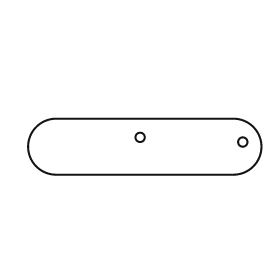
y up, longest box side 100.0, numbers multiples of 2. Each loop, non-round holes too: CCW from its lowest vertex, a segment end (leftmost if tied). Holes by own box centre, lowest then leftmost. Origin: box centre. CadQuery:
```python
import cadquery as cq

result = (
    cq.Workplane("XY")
    .moveTo(-38.0, -12.0)
    .lineTo(38.0, -12.0)
    .threePointArc((50.0, 0.0), (38.0, 12.0))
    .lineTo(-38.0, 12.0)
    .threePointArc((-50.0, 0.0), (-38.0, -12.0))
    .close()
    .moveTo(42.0, 2.0)
    .circle(2.0)
    .moveTo(-2.0, 4.0)
    .circle(2.0)
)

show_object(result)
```